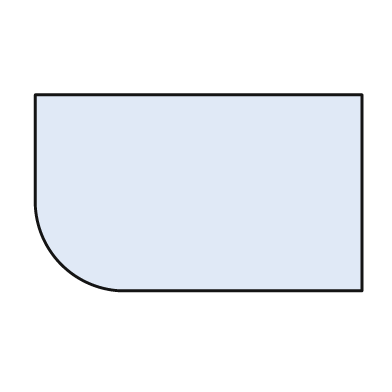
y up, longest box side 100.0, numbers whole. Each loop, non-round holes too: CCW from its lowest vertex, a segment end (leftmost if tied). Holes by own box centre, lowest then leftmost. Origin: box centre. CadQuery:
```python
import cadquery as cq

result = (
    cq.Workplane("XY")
    .moveTo(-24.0, -30.0)
    .lineTo(50.0, -30.0)
    .lineTo(50.0, 30.0)
    .lineTo(-50.0, 30.0)
    .lineTo(-50.0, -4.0)
    .threePointArc((-42.0, -22.0), (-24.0, -30.0))
    .close()
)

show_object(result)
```